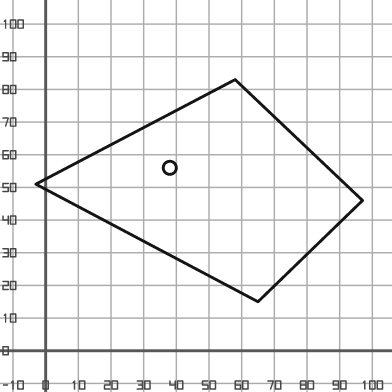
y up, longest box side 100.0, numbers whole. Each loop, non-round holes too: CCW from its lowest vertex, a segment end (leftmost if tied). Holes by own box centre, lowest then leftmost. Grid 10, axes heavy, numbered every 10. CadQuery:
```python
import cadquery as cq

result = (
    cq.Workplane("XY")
    .moveTo(65.0, 15.0)
    .lineTo(97.0, 46.0)
    .lineTo(58.0, 83.0)
    .lineTo(-3.0, 51.0)
    .close()
    .moveTo(38.0, 56.0)
    .circle(2.0)
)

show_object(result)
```